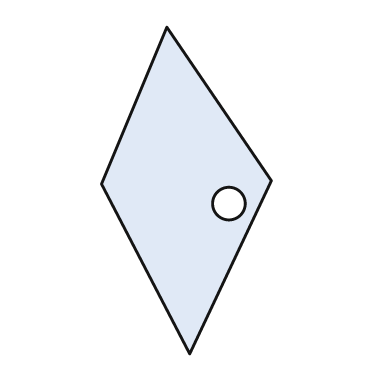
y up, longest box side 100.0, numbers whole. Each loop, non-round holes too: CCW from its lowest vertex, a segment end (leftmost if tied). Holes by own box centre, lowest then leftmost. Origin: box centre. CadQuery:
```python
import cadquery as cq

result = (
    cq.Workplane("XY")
    .moveTo(1.0, -50.0)
    .lineTo(26.0, 3.0)
    .lineTo(-6.0, 50.0)
    .lineTo(-26.0, 2.0)
    .close()
    .moveTo(13.0, -4.0)
    .circle(5.0)
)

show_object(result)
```